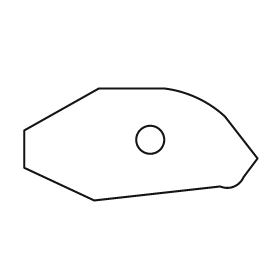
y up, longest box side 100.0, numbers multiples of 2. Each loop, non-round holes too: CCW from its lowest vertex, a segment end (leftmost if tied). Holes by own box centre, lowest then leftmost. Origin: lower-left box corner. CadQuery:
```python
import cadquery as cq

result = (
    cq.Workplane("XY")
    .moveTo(30.0, 0.0)
    .lineTo(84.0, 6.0)
    .threePointArc((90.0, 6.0), (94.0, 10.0))
    .lineTo(100.0, 18.0)
    .lineTo(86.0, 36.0)
    .threePointArc((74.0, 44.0), (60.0, 48.0))
    .lineTo(32.0, 48.0)
    .lineTo(0.0, 30.0)
    .lineTo(0.0, 14.0)
    .close()
    .moveTo(54.0, 26.0)
    .circle(6.0)
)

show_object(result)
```